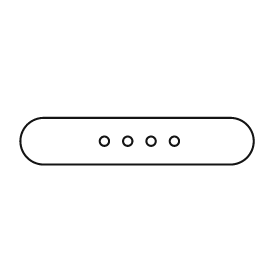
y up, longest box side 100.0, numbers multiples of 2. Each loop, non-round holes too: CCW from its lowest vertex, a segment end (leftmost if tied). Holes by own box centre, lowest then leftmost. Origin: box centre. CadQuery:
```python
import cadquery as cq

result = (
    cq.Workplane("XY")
    .moveTo(-40.0, -10.0)
    .lineTo(40.0, -10.0)
    .threePointArc((50.0, 0.0), (40.0, 10.0))
    .lineTo(-40.0, 10.0)
    .threePointArc((-50.0, 0.0), (-40.0, -10.0))
    .close()
    .moveTo(-14.0, 0.0)
    .circle(2.0)
    .moveTo(-4.0, 0.0)
    .circle(2.0)
    .moveTo(6.0, 0.0)
    .circle(2.0)
    .moveTo(16.0, 0.0)
    .circle(2.0)
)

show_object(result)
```